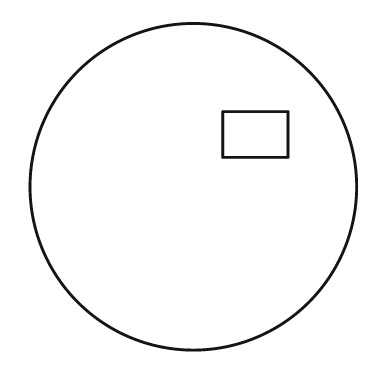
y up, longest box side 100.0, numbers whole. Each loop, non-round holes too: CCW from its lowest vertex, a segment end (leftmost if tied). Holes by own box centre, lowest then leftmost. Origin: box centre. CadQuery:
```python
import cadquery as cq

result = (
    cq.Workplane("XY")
    .moveTo(0.0, 0.0)
    .circle(50.0)
    .moveTo(9.0, 9.0)
    .lineTo(29.0, 9.0)
    .lineTo(29.0, 23.0)
    .lineTo(9.0, 23.0)
    .close()
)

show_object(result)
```